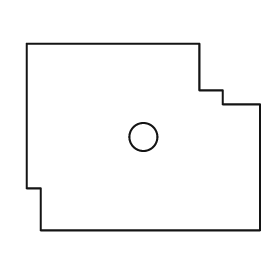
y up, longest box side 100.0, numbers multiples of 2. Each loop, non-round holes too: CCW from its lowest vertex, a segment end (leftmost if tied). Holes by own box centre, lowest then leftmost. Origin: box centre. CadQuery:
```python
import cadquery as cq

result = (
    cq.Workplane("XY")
    .moveTo(-44.0, -40.0)
    .lineTo(50.0, -40.0)
    .lineTo(50.0, 14.0)
    .lineTo(34.0, 14.0)
    .lineTo(34.0, 20.0)
    .lineTo(24.0, 20.0)
    .lineTo(24.0, 40.0)
    .lineTo(-50.0, 40.0)
    .lineTo(-50.0, -22.0)
    .lineTo(-44.0, -22.0)
    .close()
    .moveTo(0.0, 0.0)
    .circle(6.0)
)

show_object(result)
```